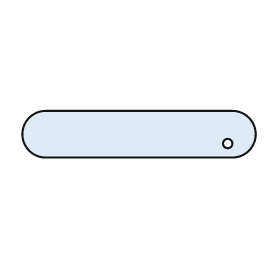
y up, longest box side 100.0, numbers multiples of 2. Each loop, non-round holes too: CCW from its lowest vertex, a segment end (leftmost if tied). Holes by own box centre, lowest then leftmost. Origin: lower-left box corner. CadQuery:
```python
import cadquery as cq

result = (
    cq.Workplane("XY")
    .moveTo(10.0, 0.0)
    .lineTo(90.0, 0.0)
    .threePointArc((100.0, 10.0), (90.0, 20.0))
    .lineTo(10.0, 20.0)
    .threePointArc((0.0, 10.0), (10.0, 0.0))
    .close()
    .moveTo(88.0, 6.0)
    .circle(2.0)
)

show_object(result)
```